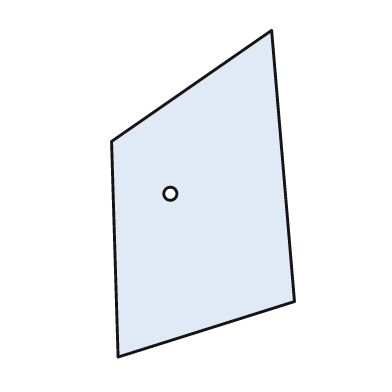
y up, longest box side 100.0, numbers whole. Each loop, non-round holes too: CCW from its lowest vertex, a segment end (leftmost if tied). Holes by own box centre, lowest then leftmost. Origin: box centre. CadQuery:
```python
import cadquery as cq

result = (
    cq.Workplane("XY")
    .moveTo(-26.0, -50.0)
    .lineTo(28.0, -33.0)
    .lineTo(21.0, 50.0)
    .lineTo(-28.0, 16.0)
    .close()
    .moveTo(-10.0, 0.0)
    .circle(2.0)
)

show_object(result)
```